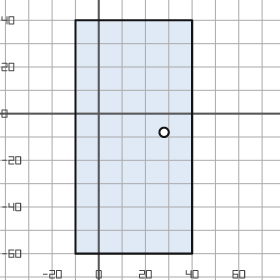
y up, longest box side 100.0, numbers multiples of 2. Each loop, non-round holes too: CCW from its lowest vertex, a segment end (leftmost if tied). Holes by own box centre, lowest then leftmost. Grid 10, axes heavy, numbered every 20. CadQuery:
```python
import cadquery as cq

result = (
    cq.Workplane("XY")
    .moveTo(-10.0, -60.0)
    .lineTo(40.0, -60.0)
    .lineTo(40.0, 40.0)
    .lineTo(-10.0, 40.0)
    .close()
    .moveTo(28.0, -8.0)
    .circle(2.0)
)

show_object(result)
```